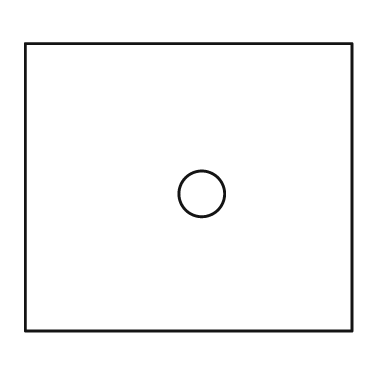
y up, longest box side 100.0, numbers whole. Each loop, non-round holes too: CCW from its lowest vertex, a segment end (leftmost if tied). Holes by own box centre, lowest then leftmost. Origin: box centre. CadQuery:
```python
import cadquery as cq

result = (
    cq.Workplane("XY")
    .moveTo(-50.0, -44.0)
    .lineTo(50.0, -44.0)
    .lineTo(50.0, 44.0)
    .lineTo(-50.0, 44.0)
    .close()
    .moveTo(4.0, -2.0)
    .circle(7.0)
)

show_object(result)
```